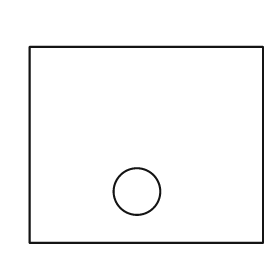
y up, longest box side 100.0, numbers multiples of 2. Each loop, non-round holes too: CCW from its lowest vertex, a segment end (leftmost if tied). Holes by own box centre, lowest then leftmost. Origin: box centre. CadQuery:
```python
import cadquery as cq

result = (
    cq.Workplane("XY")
    .moveTo(-50.0, -42.0)
    .lineTo(50.0, -42.0)
    .lineTo(50.0, 42.0)
    .lineTo(-50.0, 42.0)
    .close()
    .moveTo(-4.0, -20.0)
    .circle(10.0)
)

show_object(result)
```